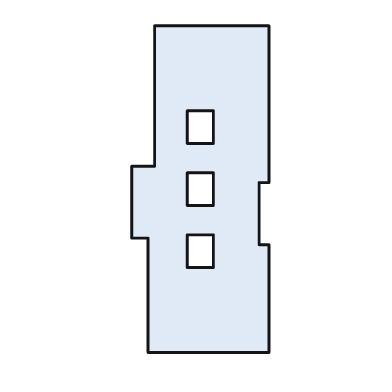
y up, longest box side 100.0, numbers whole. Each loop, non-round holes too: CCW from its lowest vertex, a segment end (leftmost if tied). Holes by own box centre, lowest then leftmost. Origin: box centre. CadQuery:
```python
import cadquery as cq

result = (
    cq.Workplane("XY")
    .moveTo(-16.0, -50.0)
    .lineTo(21.0, -50.0)
    .lineTo(21.0, -17.0)
    .lineTo(18.0, -17.0)
    .lineTo(18.0, 2.0)
    .lineTo(21.0, 2.0)
    .lineTo(21.0, 50.0)
    .lineTo(-14.0, 50.0)
    .lineTo(-14.0, 7.0)
    .lineTo(-21.0, 7.0)
    .lineTo(-21.0, -15.0)
    .lineTo(-16.0, -15.0)
    .close()
    .moveTo(-4.0, -24.0)
    .lineTo(4.0, -24.0)
    .lineTo(4.0, -14.0)
    .lineTo(-4.0, -14.0)
    .close()
    .moveTo(-4.0, -5.0)
    .lineTo(4.0, -5.0)
    .lineTo(4.0, 5.0)
    .lineTo(-4.0, 5.0)
    .close()
    .moveTo(-4.0, 14.0)
    .lineTo(4.0, 14.0)
    .lineTo(4.0, 24.0)
    .lineTo(-4.0, 24.0)
    .close()
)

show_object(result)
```